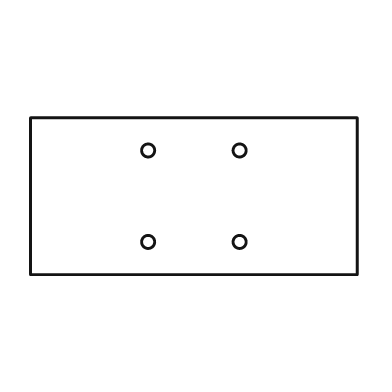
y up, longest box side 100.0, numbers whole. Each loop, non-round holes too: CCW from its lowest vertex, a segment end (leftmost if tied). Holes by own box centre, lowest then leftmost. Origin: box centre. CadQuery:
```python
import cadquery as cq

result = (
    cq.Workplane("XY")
    .moveTo(-50.0, -24.0)
    .lineTo(50.0, -24.0)
    .lineTo(50.0, 24.0)
    .lineTo(-50.0, 24.0)
    .close()
    .moveTo(-14.0, -14.0)
    .circle(2.0)
    .moveTo(14.0, -14.0)
    .circle(2.0)
    .moveTo(-14.0, 14.0)
    .circle(2.0)
    .moveTo(14.0, 14.0)
    .circle(2.0)
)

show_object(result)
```